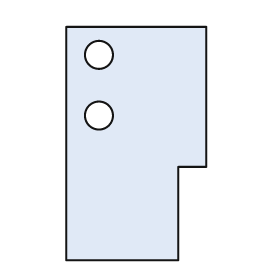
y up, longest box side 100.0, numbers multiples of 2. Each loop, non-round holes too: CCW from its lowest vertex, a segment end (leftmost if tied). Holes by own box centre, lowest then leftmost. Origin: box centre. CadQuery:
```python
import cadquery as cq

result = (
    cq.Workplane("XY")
    .moveTo(-30.0, -50.0)
    .lineTo(18.0, -50.0)
    .lineTo(18.0, -10.0)
    .lineTo(30.0, -10.0)
    .lineTo(30.0, 50.0)
    .lineTo(-30.0, 50.0)
    .close()
    .moveTo(-16.0, 12.0)
    .circle(6.0)
    .moveTo(-16.0, 38.0)
    .circle(6.0)
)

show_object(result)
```